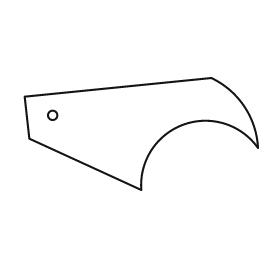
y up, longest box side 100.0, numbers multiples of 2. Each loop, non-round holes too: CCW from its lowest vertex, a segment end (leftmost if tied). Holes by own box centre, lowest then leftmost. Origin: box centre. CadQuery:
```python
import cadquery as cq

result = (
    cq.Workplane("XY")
    .moveTo(0.0, -24.0)
    .threePointArc((18.0, 4.0), (50.0, -6.0))
    .threePointArc((44.0, 12.0), (30.0, 24.0))
    .lineTo(-50.0, 16.0)
    .lineTo(-48.0, -2.0)
    .close()
    .moveTo(-38.0, 8.0)
    .circle(2.0)
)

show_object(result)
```